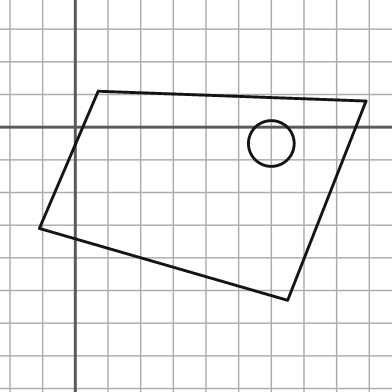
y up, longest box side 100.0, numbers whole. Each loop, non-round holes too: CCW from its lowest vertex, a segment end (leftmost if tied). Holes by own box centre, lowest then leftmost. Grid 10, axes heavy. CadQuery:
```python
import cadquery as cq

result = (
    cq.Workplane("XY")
    .moveTo(65.0, -53.0)
    .lineTo(89.0, 8.0)
    .lineTo(7.0, 11.0)
    .lineTo(-11.0, -31.0)
    .close()
    .moveTo(60.0, -5.0)
    .circle(7.0)
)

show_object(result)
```